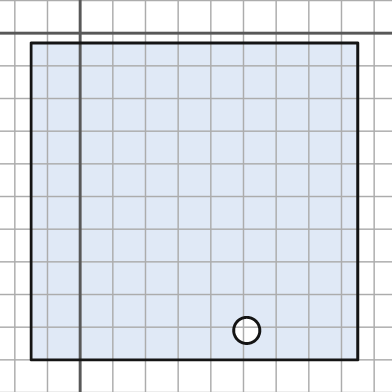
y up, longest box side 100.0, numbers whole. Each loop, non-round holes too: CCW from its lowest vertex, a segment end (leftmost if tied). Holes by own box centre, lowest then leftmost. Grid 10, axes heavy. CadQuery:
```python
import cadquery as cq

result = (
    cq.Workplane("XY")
    .moveTo(-15.0, -100.0)
    .lineTo(85.0, -100.0)
    .lineTo(85.0, -3.0)
    .lineTo(-15.0, -3.0)
    .close()
    .moveTo(51.0, -91.0)
    .circle(4.0)
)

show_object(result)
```